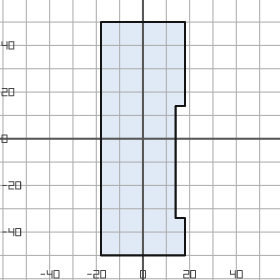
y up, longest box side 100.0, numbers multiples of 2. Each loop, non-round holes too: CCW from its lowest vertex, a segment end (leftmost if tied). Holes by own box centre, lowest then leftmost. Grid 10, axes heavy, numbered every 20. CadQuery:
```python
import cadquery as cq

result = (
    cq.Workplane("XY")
    .moveTo(-18.0, -50.0)
    .lineTo(18.0, -50.0)
    .lineTo(18.0, -34.0)
    .lineTo(14.0, -34.0)
    .lineTo(14.0, 14.0)
    .lineTo(18.0, 14.0)
    .lineTo(18.0, 50.0)
    .lineTo(-18.0, 50.0)
    .close()
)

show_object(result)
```